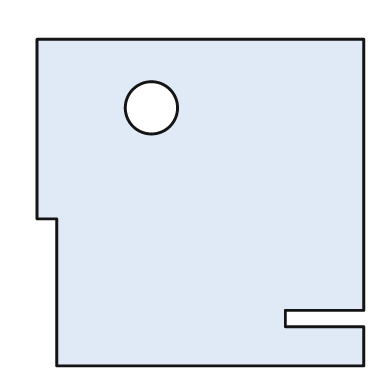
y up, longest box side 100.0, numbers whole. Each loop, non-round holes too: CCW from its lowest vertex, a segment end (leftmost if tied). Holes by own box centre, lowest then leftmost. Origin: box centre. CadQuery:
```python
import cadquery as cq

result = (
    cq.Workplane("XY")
    .moveTo(-44.0, -50.0)
    .lineTo(50.0, -50.0)
    .lineTo(50.0, -38.0)
    .lineTo(26.0, -38.0)
    .lineTo(26.0, -33.0)
    .lineTo(50.0, -33.0)
    .lineTo(50.0, 50.0)
    .lineTo(-50.0, 50.0)
    .lineTo(-50.0, -5.0)
    .lineTo(-44.0, -5.0)
    .close()
    .moveTo(-15.0, 29.0)
    .circle(8.0)
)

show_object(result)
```